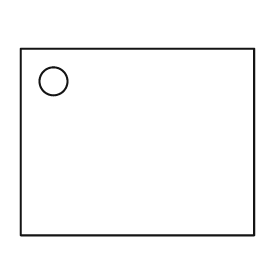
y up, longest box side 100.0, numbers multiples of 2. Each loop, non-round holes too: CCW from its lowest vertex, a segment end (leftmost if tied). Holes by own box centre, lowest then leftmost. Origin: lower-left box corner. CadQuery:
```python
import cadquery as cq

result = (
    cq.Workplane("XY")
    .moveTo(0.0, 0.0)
    .lineTo(100.0, 0.0)
    .lineTo(100.0, 80.0)
    .lineTo(0.0, 80.0)
    .close()
    .moveTo(14.0, 66.0)
    .circle(6.0)
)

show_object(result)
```